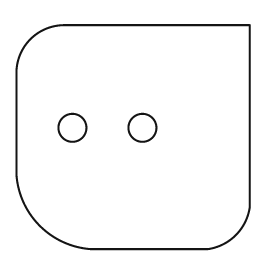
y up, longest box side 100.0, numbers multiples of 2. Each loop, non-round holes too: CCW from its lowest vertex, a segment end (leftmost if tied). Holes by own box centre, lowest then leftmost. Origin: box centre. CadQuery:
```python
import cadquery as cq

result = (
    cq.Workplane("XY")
    .moveTo(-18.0, -48.0)
    .lineTo(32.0, -48.0)
    .threePointArc((44.0, -42.0), (50.0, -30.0))
    .lineTo(50.0, 48.0)
    .lineTo(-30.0, 48.0)
    .threePointArc((-44.0, 42.0), (-50.0, 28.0))
    .lineTo(-50.0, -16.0)
    .threePointArc((-40.0, -38.0), (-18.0, -48.0))
    .close()
    .moveTo(-26.0, 4.0)
    .circle(6.0)
    .moveTo(4.0, 4.0)
    .circle(6.0)
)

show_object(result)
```